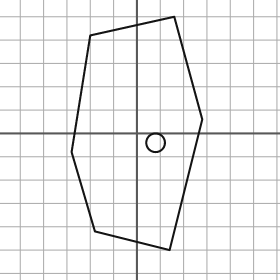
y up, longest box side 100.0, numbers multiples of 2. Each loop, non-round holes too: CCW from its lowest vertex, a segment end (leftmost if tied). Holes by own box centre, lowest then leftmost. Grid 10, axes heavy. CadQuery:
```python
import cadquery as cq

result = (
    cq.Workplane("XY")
    .moveTo(14.0, -50.0)
    .lineTo(28.0, 6.0)
    .lineTo(16.0, 50.0)
    .lineTo(-20.0, 42.0)
    .lineTo(-28.0, -8.0)
    .lineTo(-18.0, -42.0)
    .close()
    .moveTo(8.0, -4.0)
    .circle(4.0)
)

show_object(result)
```